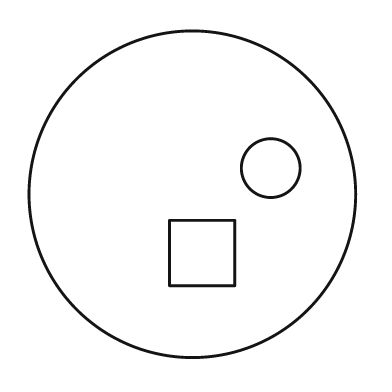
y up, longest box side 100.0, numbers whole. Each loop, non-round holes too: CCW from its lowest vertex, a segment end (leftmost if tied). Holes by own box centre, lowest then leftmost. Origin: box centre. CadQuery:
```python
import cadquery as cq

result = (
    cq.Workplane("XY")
    .moveTo(0.0, 0.0)
    .circle(50.0)
    .moveTo(-7.0, -28.0)
    .lineTo(13.0, -28.0)
    .lineTo(13.0, -8.0)
    .lineTo(-7.0, -8.0)
    .close()
    .moveTo(24.0, 8.0)
    .circle(9.0)
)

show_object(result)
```